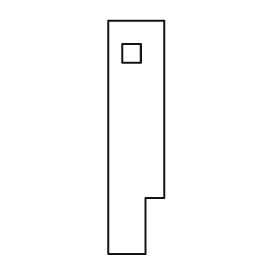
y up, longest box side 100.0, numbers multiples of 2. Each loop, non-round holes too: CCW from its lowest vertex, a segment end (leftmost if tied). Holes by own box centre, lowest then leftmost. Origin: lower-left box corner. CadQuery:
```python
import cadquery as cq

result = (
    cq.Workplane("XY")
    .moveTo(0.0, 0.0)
    .lineTo(16.0, 0.0)
    .lineTo(16.0, 24.0)
    .lineTo(24.0, 24.0)
    .lineTo(24.0, 100.0)
    .lineTo(0.0, 100.0)
    .close()
    .moveTo(6.0, 82.0)
    .lineTo(14.0, 82.0)
    .lineTo(14.0, 90.0)
    .lineTo(6.0, 90.0)
    .close()
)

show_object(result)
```